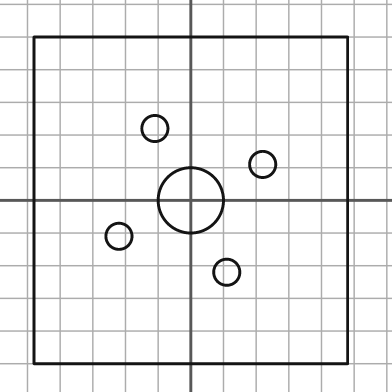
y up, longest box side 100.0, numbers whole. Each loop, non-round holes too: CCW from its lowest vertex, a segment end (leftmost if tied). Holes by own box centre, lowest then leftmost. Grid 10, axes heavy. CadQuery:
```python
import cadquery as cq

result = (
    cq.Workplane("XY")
    .moveTo(-48.0, -50.0)
    .lineTo(48.0, -50.0)
    .lineTo(48.0, 50.0)
    .lineTo(-48.0, 50.0)
    .close()
    .moveTo(11.0, -22.0)
    .circle(4.0)
    .moveTo(-22.0, -11.0)
    .circle(4.0)
    .moveTo(0.0, 0.0)
    .circle(10.0)
    .moveTo(22.0, 11.0)
    .circle(4.0)
    .moveTo(-11.0, 22.0)
    .circle(4.0)
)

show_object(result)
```